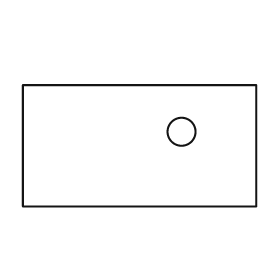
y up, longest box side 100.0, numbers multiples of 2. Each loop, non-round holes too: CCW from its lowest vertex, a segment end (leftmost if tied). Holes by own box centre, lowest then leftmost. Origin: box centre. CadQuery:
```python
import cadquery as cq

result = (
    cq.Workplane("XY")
    .moveTo(-50.0, -26.0)
    .lineTo(50.0, -26.0)
    .lineTo(50.0, 26.0)
    .lineTo(-50.0, 26.0)
    .close()
    .moveTo(18.0, 6.0)
    .circle(6.0)
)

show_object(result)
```